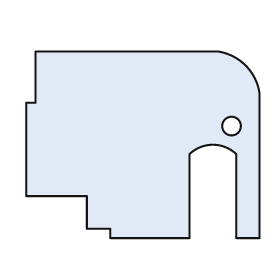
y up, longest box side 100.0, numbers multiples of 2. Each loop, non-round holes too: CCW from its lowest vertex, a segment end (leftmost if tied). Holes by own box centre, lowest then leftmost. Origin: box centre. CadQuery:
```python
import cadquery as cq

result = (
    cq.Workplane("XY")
    .moveTo(-14.0, -40.0)
    .lineTo(20.0, -40.0)
    .lineTo(20.0, -4.0)
    .threePointArc((30.0, 0.0), (40.0, -4.0))
    .lineTo(40.0, -40.0)
    .lineTo(50.0, -40.0)
    .lineTo(50.0, 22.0)
    .threePointArc((44.0, 34.0), (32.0, 40.0))
    .lineTo(-46.0, 40.0)
    .lineTo(-46.0, 18.0)
    .lineTo(-50.0, 18.0)
    .lineTo(-50.0, -22.0)
    .lineTo(-24.0, -22.0)
    .lineTo(-24.0, -36.0)
    .lineTo(-14.0, -36.0)
    .close()
    .moveTo(38.0, 8.0)
    .circle(4.0)
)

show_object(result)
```